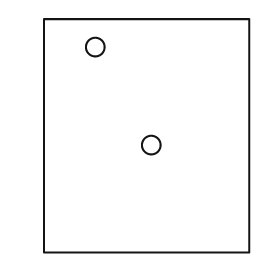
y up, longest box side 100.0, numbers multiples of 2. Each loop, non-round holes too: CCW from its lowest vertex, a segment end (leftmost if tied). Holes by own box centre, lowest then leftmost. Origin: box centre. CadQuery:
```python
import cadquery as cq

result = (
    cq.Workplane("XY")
    .moveTo(-44.0, -50.0)
    .lineTo(44.0, -50.0)
    .lineTo(44.0, 50.0)
    .lineTo(-44.0, 50.0)
    .close()
    .moveTo(2.0, -4.0)
    .circle(4.0)
    .moveTo(-22.0, 38.0)
    .circle(4.0)
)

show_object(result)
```